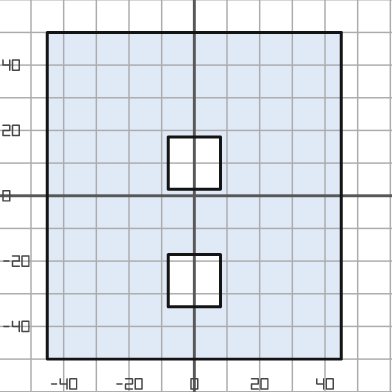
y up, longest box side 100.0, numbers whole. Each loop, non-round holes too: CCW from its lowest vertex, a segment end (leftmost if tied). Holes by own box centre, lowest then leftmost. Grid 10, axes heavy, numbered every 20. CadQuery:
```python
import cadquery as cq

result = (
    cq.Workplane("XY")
    .moveTo(-45.0, -50.0)
    .lineTo(45.0, -50.0)
    .lineTo(45.0, 50.0)
    .lineTo(-45.0, 50.0)
    .close()
    .moveTo(-8.0, -34.0)
    .lineTo(8.0, -34.0)
    .lineTo(8.0, -18.0)
    .lineTo(-8.0, -18.0)
    .close()
    .moveTo(-8.0, 2.0)
    .lineTo(8.0, 2.0)
    .lineTo(8.0, 18.0)
    .lineTo(-8.0, 18.0)
    .close()
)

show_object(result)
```